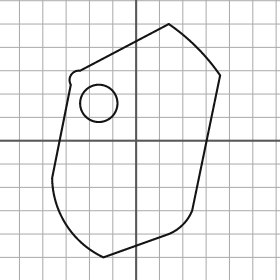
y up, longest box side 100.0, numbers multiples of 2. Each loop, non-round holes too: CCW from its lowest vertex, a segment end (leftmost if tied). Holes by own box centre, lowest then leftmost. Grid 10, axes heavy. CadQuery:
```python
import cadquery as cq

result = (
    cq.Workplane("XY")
    .moveTo(-14.0, -50.0)
    .lineTo(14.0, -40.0)
    .threePointArc((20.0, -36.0), (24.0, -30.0))
    .lineTo(36.0, 28.0)
    .threePointArc((26.0, 40.0), (14.0, 50.0))
    .lineTo(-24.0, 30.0)
    .threePointArc((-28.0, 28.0), (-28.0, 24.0))
    .lineTo(-36.0, -16.0)
    .threePointArc((-30.0, -36.0), (-14.0, -50.0))
    .close()
    .moveTo(-16.0, 16.0)
    .circle(8.0)
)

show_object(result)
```